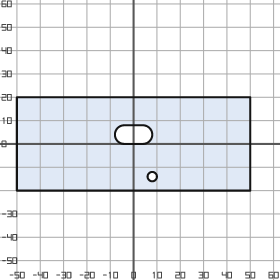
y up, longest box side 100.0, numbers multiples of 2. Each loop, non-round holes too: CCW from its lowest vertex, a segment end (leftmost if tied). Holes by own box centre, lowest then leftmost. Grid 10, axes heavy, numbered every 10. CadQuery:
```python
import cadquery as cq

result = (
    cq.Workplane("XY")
    .moveTo(-50.0, -20.0)
    .lineTo(50.0, -20.0)
    .lineTo(50.0, 20.0)
    .lineTo(-50.0, 20.0)
    .close()
    .moveTo(8.0, -14.0)
    .circle(2.0)
    .moveTo(-4.0, 0.0)
    .lineTo(4.0, 0.0)
    .threePointArc((8.0, 4.0), (4.0, 8.0))
    .lineTo(-4.0, 8.0)
    .threePointArc((-8.0, 4.0), (-4.0, 0.0))
    .close()
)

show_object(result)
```